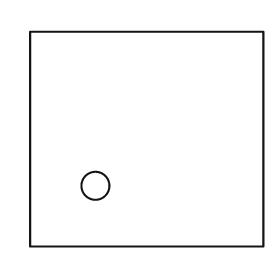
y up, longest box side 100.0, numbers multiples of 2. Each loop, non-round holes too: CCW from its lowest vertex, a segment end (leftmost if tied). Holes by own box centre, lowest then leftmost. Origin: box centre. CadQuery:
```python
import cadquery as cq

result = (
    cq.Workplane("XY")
    .moveTo(-50.0, -46.0)
    .lineTo(50.0, -46.0)
    .lineTo(50.0, 46.0)
    .lineTo(-50.0, 46.0)
    .close()
    .moveTo(-22.0, -20.0)
    .circle(6.0)
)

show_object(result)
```